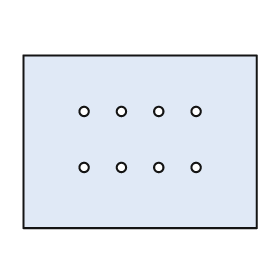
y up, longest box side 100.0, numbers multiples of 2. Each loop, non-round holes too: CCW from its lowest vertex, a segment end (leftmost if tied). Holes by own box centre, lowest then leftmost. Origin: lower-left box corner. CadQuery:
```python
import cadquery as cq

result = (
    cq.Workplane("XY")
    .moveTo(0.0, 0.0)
    .lineTo(100.0, 0.0)
    .lineTo(100.0, 74.0)
    .lineTo(0.0, 74.0)
    .close()
    .moveTo(26.0, 26.0)
    .circle(2.0)
    .moveTo(42.0, 26.0)
    .circle(2.0)
    .moveTo(58.0, 26.0)
    .circle(2.0)
    .moveTo(74.0, 26.0)
    .circle(2.0)
    .moveTo(26.0, 50.0)
    .circle(2.0)
    .moveTo(42.0, 50.0)
    .circle(2.0)
    .moveTo(58.0, 50.0)
    .circle(2.0)
    .moveTo(74.0, 50.0)
    .circle(2.0)
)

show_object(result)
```